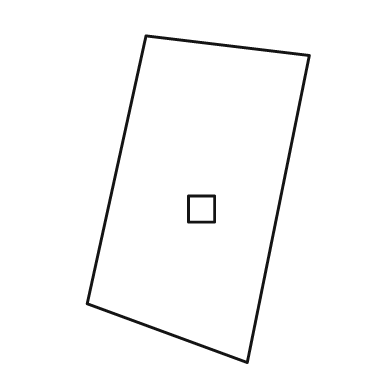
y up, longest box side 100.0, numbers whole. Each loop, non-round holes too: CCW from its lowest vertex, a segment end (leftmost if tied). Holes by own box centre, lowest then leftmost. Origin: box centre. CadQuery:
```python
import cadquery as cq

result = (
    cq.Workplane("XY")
    .moveTo(15.0, -50.0)
    .lineTo(34.0, 44.0)
    .lineTo(-16.0, 50.0)
    .lineTo(-34.0, -32.0)
    .close()
    .moveTo(-3.0, -7.0)
    .lineTo(5.0, -7.0)
    .lineTo(5.0, 1.0)
    .lineTo(-3.0, 1.0)
    .close()
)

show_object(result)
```